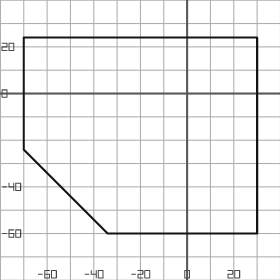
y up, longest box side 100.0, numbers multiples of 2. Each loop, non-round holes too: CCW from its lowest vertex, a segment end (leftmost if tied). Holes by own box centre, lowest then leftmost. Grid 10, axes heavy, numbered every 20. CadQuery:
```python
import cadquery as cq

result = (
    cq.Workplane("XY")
    .moveTo(-34.0, -60.0)
    .lineTo(30.0, -60.0)
    .lineTo(30.0, 24.0)
    .lineTo(-70.0, 24.0)
    .lineTo(-70.0, -24.0)
    .close()
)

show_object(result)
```